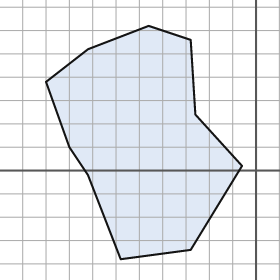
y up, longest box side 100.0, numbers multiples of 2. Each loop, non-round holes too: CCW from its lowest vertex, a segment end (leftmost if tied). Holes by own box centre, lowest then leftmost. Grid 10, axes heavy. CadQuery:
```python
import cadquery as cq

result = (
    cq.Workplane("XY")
    .moveTo(-58.0, -38.0)
    .lineTo(-28.0, -34.0)
    .lineTo(-6.0, 2.0)
    .lineTo(-26.0, 24.0)
    .lineTo(-28.0, 56.0)
    .lineTo(-46.0, 62.0)
    .lineTo(-72.0, 52.0)
    .lineTo(-90.0, 38.0)
    .lineTo(-80.0, 10.0)
    .lineTo(-72.0, -2.0)
    .close()
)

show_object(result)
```